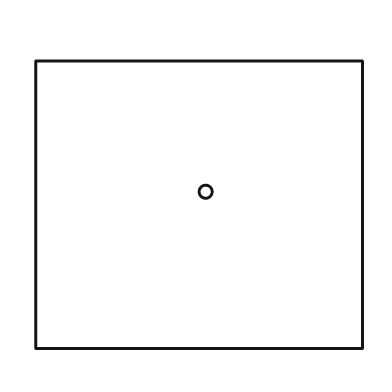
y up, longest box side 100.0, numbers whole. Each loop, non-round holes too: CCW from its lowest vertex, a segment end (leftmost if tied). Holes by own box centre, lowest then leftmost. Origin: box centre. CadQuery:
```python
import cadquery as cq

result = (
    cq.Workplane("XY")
    .moveTo(-50.0, -44.0)
    .lineTo(50.0, -44.0)
    .lineTo(50.0, 44.0)
    .lineTo(-50.0, 44.0)
    .close()
    .moveTo(2.0, 4.0)
    .circle(2.0)
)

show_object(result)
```